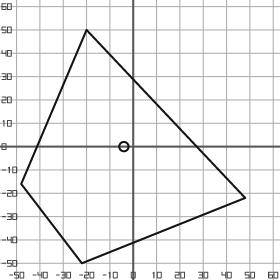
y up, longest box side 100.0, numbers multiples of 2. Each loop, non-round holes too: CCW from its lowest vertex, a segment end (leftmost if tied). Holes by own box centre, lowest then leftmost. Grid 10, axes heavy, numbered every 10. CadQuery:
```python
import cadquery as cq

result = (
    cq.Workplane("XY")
    .moveTo(-22.0, -50.0)
    .lineTo(48.0, -22.0)
    .lineTo(-20.0, 50.0)
    .lineTo(-48.0, -16.0)
    .close()
    .moveTo(-4.0, 0.0)
    .circle(2.0)
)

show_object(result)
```